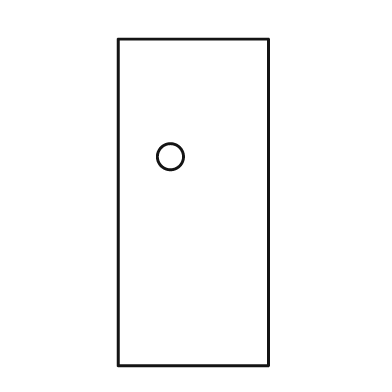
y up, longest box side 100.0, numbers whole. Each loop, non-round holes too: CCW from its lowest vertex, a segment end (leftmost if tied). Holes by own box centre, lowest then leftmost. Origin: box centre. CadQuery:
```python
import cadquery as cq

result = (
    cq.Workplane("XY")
    .moveTo(-23.0, -50.0)
    .lineTo(23.0, -50.0)
    .lineTo(23.0, 50.0)
    .lineTo(-23.0, 50.0)
    .close()
    .moveTo(-7.0, 14.0)
    .circle(4.0)
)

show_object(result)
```